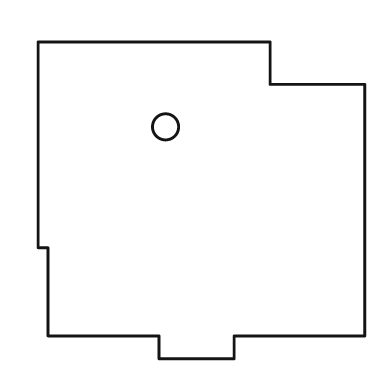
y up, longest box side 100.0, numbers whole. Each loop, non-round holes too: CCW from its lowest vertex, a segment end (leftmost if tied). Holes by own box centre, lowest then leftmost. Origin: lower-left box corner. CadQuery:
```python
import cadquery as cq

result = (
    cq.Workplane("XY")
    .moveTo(37.0, 0.0)
    .lineTo(60.0, 0.0)
    .lineTo(60.0, 7.0)
    .lineTo(100.0, 7.0)
    .lineTo(100.0, 84.0)
    .lineTo(71.0, 84.0)
    .lineTo(71.0, 97.0)
    .lineTo(0.0, 97.0)
    .lineTo(0.0, 34.0)
    .lineTo(3.0, 34.0)
    .lineTo(3.0, 7.0)
    .lineTo(37.0, 7.0)
    .close()
    .moveTo(39.0, 71.0)
    .circle(4.0)
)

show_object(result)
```